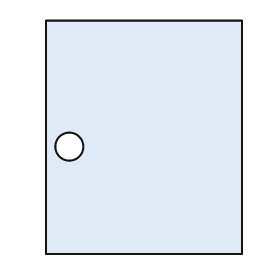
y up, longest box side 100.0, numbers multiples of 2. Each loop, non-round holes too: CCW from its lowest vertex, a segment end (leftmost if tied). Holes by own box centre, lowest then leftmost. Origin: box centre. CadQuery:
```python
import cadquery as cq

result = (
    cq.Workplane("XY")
    .moveTo(-42.0, -50.0)
    .lineTo(42.0, -50.0)
    .lineTo(42.0, 50.0)
    .lineTo(-42.0, 50.0)
    .close()
    .moveTo(-32.0, -4.0)
    .circle(6.0)
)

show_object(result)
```